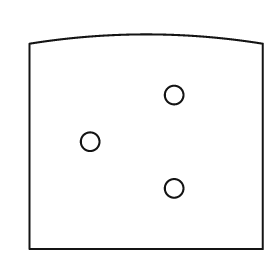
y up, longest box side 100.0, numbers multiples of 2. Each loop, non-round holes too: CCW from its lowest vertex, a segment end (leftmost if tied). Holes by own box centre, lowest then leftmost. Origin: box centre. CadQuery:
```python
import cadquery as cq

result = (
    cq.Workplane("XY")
    .moveTo(-50.0, -46.0)
    .lineTo(50.0, -46.0)
    .lineTo(50.0, 42.0)
    .threePointArc((0.0, 46.0), (-50.0, 42.0))
    .close()
    .moveTo(12.0, -20.0)
    .circle(4.0)
    .moveTo(-24.0, 0.0)
    .circle(4.0)
    .moveTo(12.0, 20.0)
    .circle(4.0)
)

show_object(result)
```